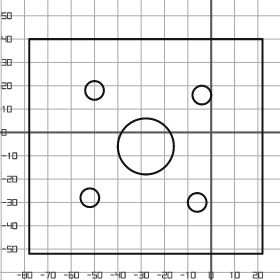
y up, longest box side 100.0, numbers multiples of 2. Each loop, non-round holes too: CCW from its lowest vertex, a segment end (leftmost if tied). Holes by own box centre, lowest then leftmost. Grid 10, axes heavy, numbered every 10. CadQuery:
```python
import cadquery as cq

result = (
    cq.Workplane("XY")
    .moveTo(-78.0, -52.0)
    .lineTo(22.0, -52.0)
    .lineTo(22.0, 40.0)
    .lineTo(-78.0, 40.0)
    .close()
    .moveTo(-6.0, -30.0)
    .circle(4.0)
    .moveTo(-52.0, -28.0)
    .circle(4.0)
    .moveTo(-28.0, -6.0)
    .circle(12.0)
    .moveTo(-4.0, 16.0)
    .circle(4.0)
    .moveTo(-50.0, 18.0)
    .circle(4.0)
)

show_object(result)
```